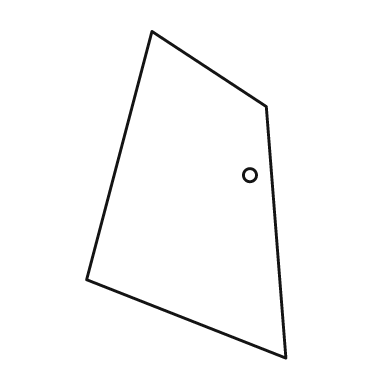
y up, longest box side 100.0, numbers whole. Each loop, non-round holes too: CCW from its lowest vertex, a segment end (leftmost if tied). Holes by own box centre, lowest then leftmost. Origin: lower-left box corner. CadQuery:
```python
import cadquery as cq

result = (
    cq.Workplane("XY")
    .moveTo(61.0, 0.0)
    .lineTo(55.0, 77.0)
    .lineTo(20.0, 100.0)
    .lineTo(0.0, 24.0)
    .close()
    .moveTo(50.0, 56.0)
    .circle(2.0)
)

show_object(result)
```